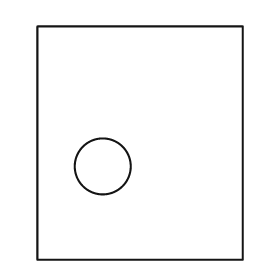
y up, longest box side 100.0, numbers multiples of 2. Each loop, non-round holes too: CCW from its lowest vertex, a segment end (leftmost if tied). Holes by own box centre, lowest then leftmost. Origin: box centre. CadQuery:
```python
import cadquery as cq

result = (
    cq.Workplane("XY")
    .moveTo(-44.0, -50.0)
    .lineTo(44.0, -50.0)
    .lineTo(44.0, 50.0)
    .lineTo(-44.0, 50.0)
    .close()
    .moveTo(-16.0, -10.0)
    .circle(12.0)
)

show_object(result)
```